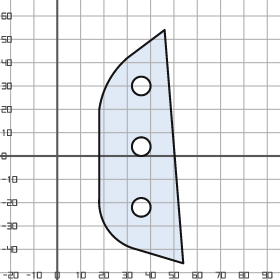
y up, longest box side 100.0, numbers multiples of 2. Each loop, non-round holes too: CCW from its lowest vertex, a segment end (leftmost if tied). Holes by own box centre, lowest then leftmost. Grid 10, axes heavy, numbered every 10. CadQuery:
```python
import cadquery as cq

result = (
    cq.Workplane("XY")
    .moveTo(54.0, -46.0)
    .lineTo(46.0, 54.0)
    .lineTo(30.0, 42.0)
    .threePointArc((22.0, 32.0), (18.0, 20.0))
    .lineTo(18.0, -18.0)
    .threePointArc((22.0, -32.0), (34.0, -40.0))
    .close()
    .moveTo(36.0, -22.0)
    .circle(4.0)
    .moveTo(36.0, 4.0)
    .circle(4.0)
    .moveTo(36.0, 30.0)
    .circle(4.0)
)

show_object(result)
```